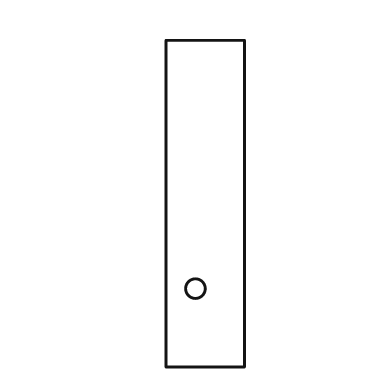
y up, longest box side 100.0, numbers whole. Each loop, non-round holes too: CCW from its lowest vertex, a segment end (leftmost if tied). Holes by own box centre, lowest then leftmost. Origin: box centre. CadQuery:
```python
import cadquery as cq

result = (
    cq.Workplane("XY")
    .moveTo(-12.0, -50.0)
    .lineTo(12.0, -50.0)
    .lineTo(12.0, 50.0)
    .lineTo(-12.0, 50.0)
    .close()
    .moveTo(-3.0, -26.0)
    .circle(3.0)
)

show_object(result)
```